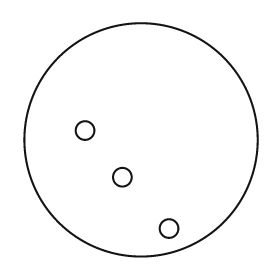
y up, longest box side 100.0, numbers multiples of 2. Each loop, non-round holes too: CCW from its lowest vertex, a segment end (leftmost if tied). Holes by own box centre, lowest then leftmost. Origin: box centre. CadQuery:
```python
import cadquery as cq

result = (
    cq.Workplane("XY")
    .moveTo(0.0, 0.0)
    .circle(50.0)
    .moveTo(12.0, -38.0)
    .circle(4.0)
    .moveTo(-8.0, -16.0)
    .circle(4.0)
    .moveTo(-24.0, 4.0)
    .circle(4.0)
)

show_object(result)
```